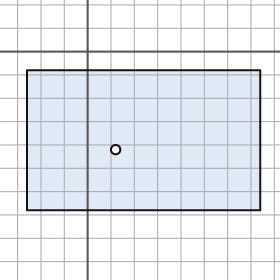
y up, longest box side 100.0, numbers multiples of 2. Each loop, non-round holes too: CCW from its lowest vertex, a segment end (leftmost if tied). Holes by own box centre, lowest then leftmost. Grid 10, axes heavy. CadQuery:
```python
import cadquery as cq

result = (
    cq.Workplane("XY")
    .moveTo(-26.0, -68.0)
    .lineTo(74.0, -68.0)
    .lineTo(74.0, -8.0)
    .lineTo(-26.0, -8.0)
    .close()
    .moveTo(12.0, -42.0)
    .circle(2.0)
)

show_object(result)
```